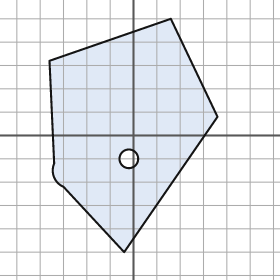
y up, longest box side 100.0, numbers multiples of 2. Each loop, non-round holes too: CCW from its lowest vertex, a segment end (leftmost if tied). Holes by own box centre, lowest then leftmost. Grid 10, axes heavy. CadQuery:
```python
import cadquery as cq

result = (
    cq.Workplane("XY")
    .moveTo(-4.0, -50.0)
    .lineTo(36.0, 8.0)
    .lineTo(16.0, 50.0)
    .lineTo(-36.0, 32.0)
    .lineTo(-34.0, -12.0)
    .threePointArc((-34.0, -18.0), (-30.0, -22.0))
    .close()
    .moveTo(-2.0, -10.0)
    .circle(4.0)
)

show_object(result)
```